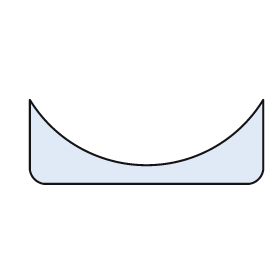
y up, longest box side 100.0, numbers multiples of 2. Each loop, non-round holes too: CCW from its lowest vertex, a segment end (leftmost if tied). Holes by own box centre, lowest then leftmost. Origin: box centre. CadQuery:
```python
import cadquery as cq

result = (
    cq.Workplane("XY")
    .moveTo(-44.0, -18.0)
    .lineTo(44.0, -18.0)
    .threePointArc((48.0, -16.0), (50.0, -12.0))
    .lineTo(50.0, 18.0)
    .threePointArc((0.0, -10.0), (-50.0, 18.0))
    .lineTo(-50.0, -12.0)
    .threePointArc((-48.0, -16.0), (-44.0, -18.0))
    .close()
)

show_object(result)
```